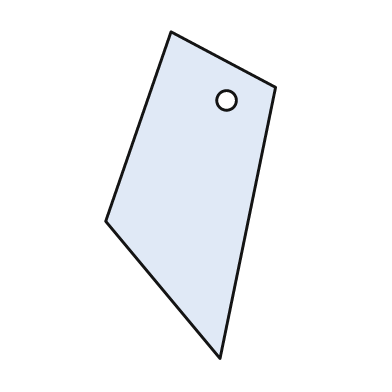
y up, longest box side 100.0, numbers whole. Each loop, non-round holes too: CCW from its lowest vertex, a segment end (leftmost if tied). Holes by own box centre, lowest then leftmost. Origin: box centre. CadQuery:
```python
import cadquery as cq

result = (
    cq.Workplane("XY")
    .moveTo(9.0, -50.0)
    .lineTo(26.0, 33.0)
    .lineTo(-6.0, 50.0)
    .lineTo(-26.0, -8.0)
    .close()
    .moveTo(11.0, 29.0)
    .circle(3.0)
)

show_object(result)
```